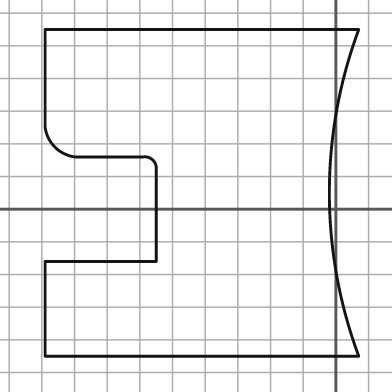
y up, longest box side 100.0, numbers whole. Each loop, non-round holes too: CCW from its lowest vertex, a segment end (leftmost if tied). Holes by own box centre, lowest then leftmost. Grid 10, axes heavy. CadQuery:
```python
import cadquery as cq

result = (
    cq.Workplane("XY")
    .moveTo(-89.0, -45.0)
    .lineTo(7.0, -45.0)
    .threePointArc((-2.0, 5.0), (7.0, 55.0))
    .lineTo(-89.0, 55.0)
    .lineTo(-89.0, 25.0)
    .threePointArc((-86.0, 19.0), (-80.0, 16.0))
    .lineTo(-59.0, 16.0)
    .threePointArc((-56.0, 15.0), (-55.0, 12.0))
    .lineTo(-55.0, -16.0)
    .lineTo(-89.0, -16.0)
    .close()
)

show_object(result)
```